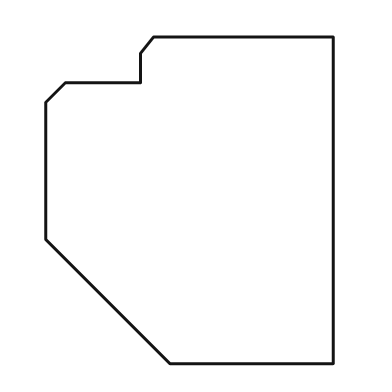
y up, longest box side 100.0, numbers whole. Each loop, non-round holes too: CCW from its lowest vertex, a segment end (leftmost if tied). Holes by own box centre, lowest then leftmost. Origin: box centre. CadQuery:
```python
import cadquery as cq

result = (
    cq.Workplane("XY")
    .moveTo(-6.0, -50.0)
    .lineTo(44.0, -50.0)
    .lineTo(44.0, 50.0)
    .lineTo(-11.0, 50.0)
    .lineTo(-15.0, 45.0)
    .lineTo(-15.0, 36.0)
    .lineTo(-38.0, 36.0)
    .lineTo(-44.0, 30.0)
    .lineTo(-44.0, -12.0)
    .close()
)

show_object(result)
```